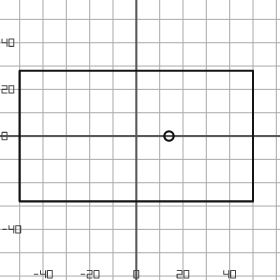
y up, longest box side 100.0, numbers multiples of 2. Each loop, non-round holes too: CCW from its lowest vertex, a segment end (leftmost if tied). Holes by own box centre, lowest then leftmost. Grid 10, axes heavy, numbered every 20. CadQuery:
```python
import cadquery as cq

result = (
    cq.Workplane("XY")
    .moveTo(-50.0, -28.0)
    .lineTo(50.0, -28.0)
    .lineTo(50.0, 28.0)
    .lineTo(-50.0, 28.0)
    .close()
    .moveTo(14.0, 0.0)
    .circle(2.0)
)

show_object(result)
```